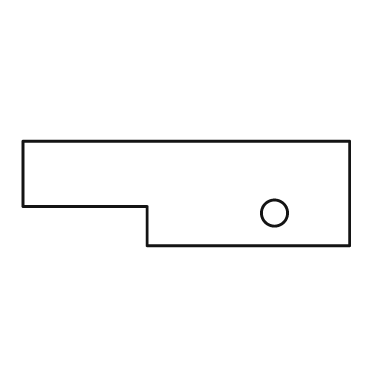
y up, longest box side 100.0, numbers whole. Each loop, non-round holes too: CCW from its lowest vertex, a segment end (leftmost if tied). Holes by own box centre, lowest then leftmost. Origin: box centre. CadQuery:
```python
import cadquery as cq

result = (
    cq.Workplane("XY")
    .moveTo(-12.0, -16.0)
    .lineTo(50.0, -16.0)
    .lineTo(50.0, 16.0)
    .lineTo(-50.0, 16.0)
    .lineTo(-50.0, -4.0)
    .lineTo(-12.0, -4.0)
    .close()
    .moveTo(27.0, -6.0)
    .circle(4.0)
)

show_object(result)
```